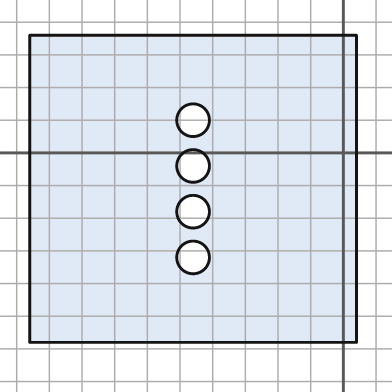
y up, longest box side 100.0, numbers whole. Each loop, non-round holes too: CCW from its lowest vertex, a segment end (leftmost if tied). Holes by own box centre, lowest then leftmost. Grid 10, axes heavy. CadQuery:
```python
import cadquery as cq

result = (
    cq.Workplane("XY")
    .moveTo(-96.0, -58.0)
    .lineTo(4.0, -58.0)
    .lineTo(4.0, 36.0)
    .lineTo(-96.0, 36.0)
    .close()
    .moveTo(-46.0, -32.0)
    .circle(5.0)
    .moveTo(-46.0, -18.0)
    .circle(5.0)
    .moveTo(-46.0, -4.0)
    .circle(5.0)
    .moveTo(-46.0, 10.0)
    .circle(5.0)
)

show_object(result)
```